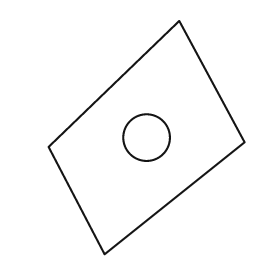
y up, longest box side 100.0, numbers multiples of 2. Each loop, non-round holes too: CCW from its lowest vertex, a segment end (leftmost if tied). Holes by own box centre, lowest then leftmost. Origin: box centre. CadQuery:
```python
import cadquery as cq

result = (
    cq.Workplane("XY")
    .moveTo(-18.0, -50.0)
    .lineTo(42.0, -2.0)
    .lineTo(14.0, 50.0)
    .lineTo(-42.0, -4.0)
    .close()
    .moveTo(0.0, 0.0)
    .circle(10.0)
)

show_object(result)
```